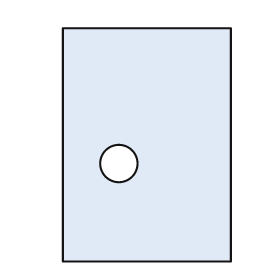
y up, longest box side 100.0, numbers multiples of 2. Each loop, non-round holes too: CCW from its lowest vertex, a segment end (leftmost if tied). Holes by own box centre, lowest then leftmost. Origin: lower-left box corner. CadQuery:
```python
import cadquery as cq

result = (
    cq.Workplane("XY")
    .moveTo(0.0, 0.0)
    .lineTo(72.0, 0.0)
    .lineTo(72.0, 100.0)
    .lineTo(0.0, 100.0)
    .close()
    .moveTo(24.0, 42.0)
    .circle(8.0)
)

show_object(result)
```